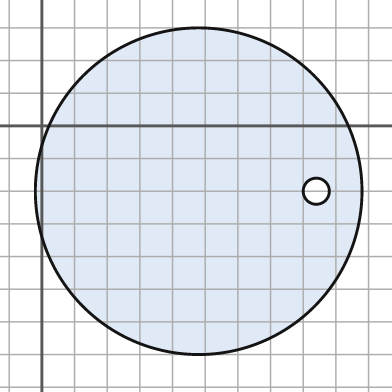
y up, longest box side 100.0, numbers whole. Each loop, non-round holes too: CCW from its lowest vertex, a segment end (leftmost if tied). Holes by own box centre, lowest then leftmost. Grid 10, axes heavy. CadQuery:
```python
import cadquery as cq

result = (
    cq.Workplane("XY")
    .moveTo(48.0, -20.0)
    .circle(50.0)
    .moveTo(84.0, -20.0)
    .circle(4.0)
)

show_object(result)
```